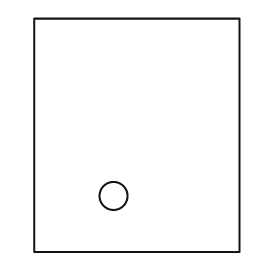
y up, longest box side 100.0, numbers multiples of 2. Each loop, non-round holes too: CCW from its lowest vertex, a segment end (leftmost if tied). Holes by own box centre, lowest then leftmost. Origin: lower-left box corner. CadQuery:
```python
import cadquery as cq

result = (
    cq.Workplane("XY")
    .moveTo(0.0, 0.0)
    .lineTo(88.0, 0.0)
    .lineTo(88.0, 100.0)
    .lineTo(0.0, 100.0)
    .close()
    .moveTo(34.0, 24.0)
    .circle(6.0)
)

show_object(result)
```